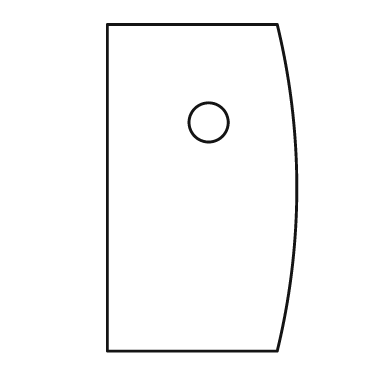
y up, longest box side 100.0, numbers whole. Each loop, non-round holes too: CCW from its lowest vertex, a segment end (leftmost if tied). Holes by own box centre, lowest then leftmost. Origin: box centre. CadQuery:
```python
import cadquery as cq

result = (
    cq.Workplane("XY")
    .moveTo(-29.0, -50.0)
    .lineTo(23.0, -50.0)
    .threePointArc((29.0, 0.0), (23.0, 50.0))
    .lineTo(-29.0, 50.0)
    .close()
    .moveTo(2.0, 20.0)
    .circle(6.0)
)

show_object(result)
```